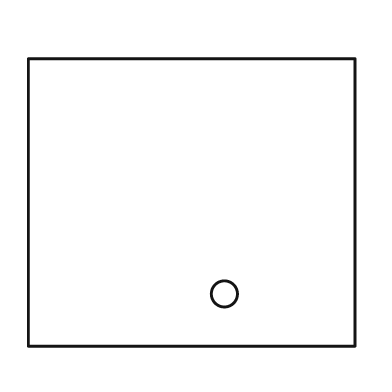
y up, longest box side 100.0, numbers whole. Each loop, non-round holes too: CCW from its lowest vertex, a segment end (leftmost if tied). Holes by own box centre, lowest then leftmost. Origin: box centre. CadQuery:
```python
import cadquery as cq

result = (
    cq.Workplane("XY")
    .moveTo(-50.0, -44.0)
    .lineTo(50.0, -44.0)
    .lineTo(50.0, 44.0)
    .lineTo(-50.0, 44.0)
    .close()
    .moveTo(10.0, -28.0)
    .circle(4.0)
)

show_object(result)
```